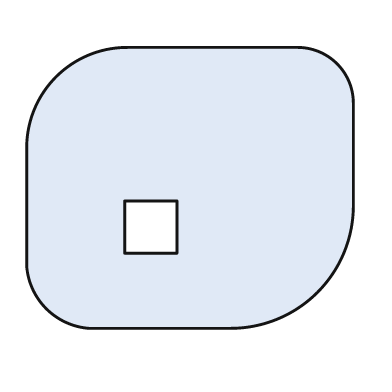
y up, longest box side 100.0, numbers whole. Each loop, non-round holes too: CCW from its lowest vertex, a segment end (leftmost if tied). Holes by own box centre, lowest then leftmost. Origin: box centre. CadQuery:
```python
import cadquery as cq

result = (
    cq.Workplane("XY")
    .moveTo(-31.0, -43.0)
    .lineTo(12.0, -43.0)
    .threePointArc((39.0, -32.0), (50.0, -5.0))
    .lineTo(50.0, 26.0)
    .threePointArc((45.0, 38.0), (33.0, 43.0))
    .lineTo(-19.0, 43.0)
    .threePointArc((-41.0, 34.0), (-50.0, 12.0))
    .lineTo(-50.0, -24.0)
    .threePointArc((-44.0, -37.0), (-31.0, -43.0))
    .close()
    .moveTo(-20.0, -20.0)
    .lineTo(-4.0, -20.0)
    .lineTo(-4.0, -4.0)
    .lineTo(-20.0, -4.0)
    .close()
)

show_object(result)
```